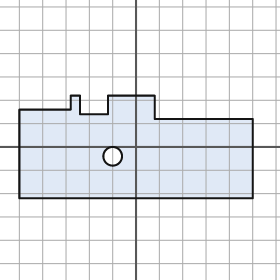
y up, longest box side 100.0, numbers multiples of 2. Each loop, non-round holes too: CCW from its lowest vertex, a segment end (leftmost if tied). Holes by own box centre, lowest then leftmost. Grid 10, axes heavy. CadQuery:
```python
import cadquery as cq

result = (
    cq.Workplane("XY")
    .moveTo(-50.0, -22.0)
    .lineTo(50.0, -22.0)
    .lineTo(50.0, 12.0)
    .lineTo(8.0, 12.0)
    .lineTo(8.0, 22.0)
    .lineTo(-12.0, 22.0)
    .lineTo(-12.0, 14.0)
    .lineTo(-24.0, 14.0)
    .lineTo(-24.0, 22.0)
    .lineTo(-28.0, 22.0)
    .lineTo(-28.0, 16.0)
    .lineTo(-50.0, 16.0)
    .close()
    .moveTo(-10.0, -4.0)
    .circle(4.0)
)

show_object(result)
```